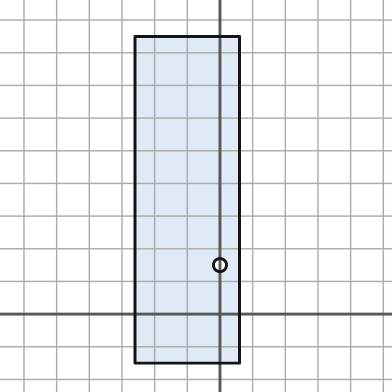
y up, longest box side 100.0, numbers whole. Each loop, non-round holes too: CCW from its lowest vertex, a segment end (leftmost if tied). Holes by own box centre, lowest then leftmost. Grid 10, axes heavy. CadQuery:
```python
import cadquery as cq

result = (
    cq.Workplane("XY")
    .moveTo(-26.0, -15.0)
    .lineTo(6.0, -15.0)
    .lineTo(6.0, 85.0)
    .lineTo(-26.0, 85.0)
    .close()
    .moveTo(0.0, 15.0)
    .circle(2.0)
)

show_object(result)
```